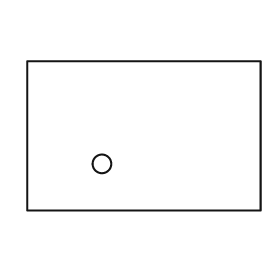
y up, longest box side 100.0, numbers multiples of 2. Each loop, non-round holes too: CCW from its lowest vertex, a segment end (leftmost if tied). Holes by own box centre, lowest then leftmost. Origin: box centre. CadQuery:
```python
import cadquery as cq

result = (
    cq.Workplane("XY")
    .moveTo(-50.0, -32.0)
    .lineTo(50.0, -32.0)
    .lineTo(50.0, 32.0)
    .lineTo(-50.0, 32.0)
    .close()
    .moveTo(-18.0, -12.0)
    .circle(4.0)
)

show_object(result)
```